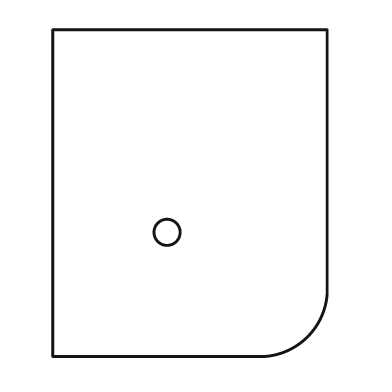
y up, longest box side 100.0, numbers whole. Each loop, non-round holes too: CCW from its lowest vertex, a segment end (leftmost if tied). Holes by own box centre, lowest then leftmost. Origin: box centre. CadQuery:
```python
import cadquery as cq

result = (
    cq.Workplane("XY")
    .moveTo(-42.0, -50.0)
    .lineTo(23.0, -50.0)
    .threePointArc((36.0, -44.0), (42.0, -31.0))
    .lineTo(42.0, 50.0)
    .lineTo(-42.0, 50.0)
    .close()
    .moveTo(-7.0, -12.0)
    .circle(4.0)
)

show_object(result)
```